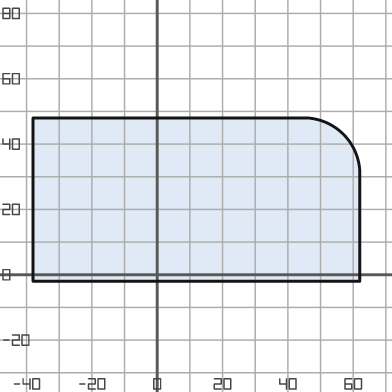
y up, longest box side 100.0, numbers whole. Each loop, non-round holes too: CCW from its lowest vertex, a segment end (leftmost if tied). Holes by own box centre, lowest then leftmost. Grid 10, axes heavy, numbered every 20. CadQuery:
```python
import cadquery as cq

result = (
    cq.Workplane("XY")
    .moveTo(-38.0, -2.0)
    .lineTo(62.0, -2.0)
    .lineTo(62.0, 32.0)
    .threePointArc((57.0, 43.0), (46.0, 48.0))
    .lineTo(-38.0, 48.0)
    .close()
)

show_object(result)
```